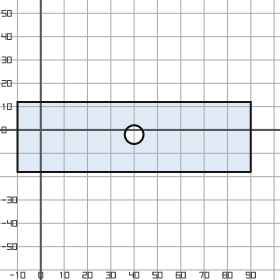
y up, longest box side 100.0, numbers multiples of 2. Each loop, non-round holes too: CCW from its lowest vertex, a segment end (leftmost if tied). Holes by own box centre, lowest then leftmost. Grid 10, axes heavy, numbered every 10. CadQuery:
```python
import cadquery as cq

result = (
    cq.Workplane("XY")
    .moveTo(-10.0, -18.0)
    .lineTo(90.0, -18.0)
    .lineTo(90.0, 12.0)
    .lineTo(-10.0, 12.0)
    .close()
    .moveTo(40.0, -2.0)
    .circle(4.0)
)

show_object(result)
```